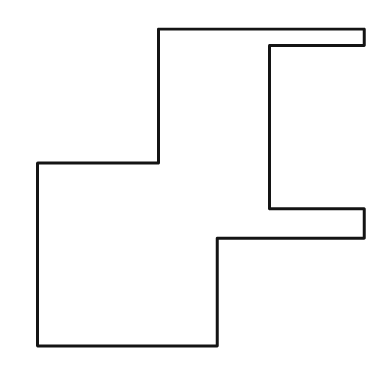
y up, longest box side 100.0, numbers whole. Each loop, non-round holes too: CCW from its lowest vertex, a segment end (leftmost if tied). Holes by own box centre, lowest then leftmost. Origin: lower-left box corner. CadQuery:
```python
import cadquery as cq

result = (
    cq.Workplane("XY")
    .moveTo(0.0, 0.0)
    .lineTo(55.0, 0.0)
    .lineTo(55.0, 33.0)
    .lineTo(100.0, 33.0)
    .lineTo(100.0, 42.0)
    .lineTo(71.0, 42.0)
    .lineTo(71.0, 92.0)
    .lineTo(100.0, 92.0)
    .lineTo(100.0, 97.0)
    .lineTo(37.0, 97.0)
    .lineTo(37.0, 56.0)
    .lineTo(0.0, 56.0)
    .close()
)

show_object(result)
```